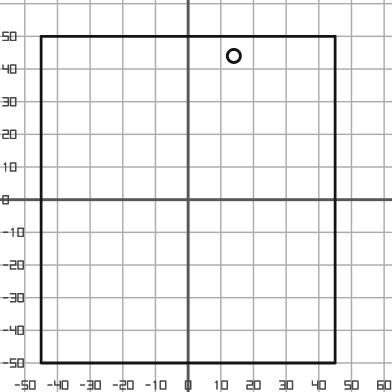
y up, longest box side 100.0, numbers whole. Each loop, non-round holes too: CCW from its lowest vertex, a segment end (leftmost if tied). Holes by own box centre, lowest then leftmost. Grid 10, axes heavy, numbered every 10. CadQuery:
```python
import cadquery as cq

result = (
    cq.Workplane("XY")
    .moveTo(-45.0, -50.0)
    .lineTo(45.0, -50.0)
    .lineTo(45.0, 50.0)
    .lineTo(-45.0, 50.0)
    .close()
    .moveTo(14.0, 44.0)
    .circle(2.0)
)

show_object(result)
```